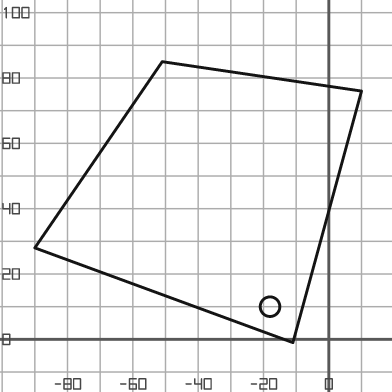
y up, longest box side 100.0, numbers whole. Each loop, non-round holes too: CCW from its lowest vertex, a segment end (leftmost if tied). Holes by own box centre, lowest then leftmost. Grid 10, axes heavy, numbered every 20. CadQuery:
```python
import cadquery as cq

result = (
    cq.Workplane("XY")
    .moveTo(-11.0, -1.0)
    .lineTo(10.0, 76.0)
    .lineTo(-51.0, 85.0)
    .lineTo(-90.0, 28.0)
    .close()
    .moveTo(-18.0, 10.0)
    .circle(3.0)
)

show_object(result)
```